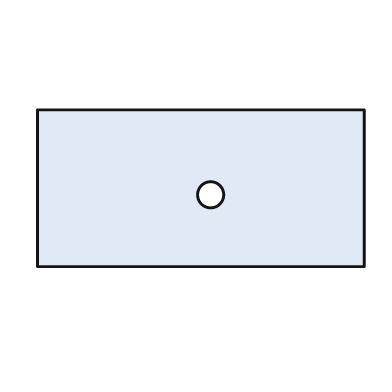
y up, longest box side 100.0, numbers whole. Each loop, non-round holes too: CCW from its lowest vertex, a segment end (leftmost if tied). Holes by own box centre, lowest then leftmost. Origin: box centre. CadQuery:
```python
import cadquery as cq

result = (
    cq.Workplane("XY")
    .moveTo(-50.0, -24.0)
    .lineTo(50.0, -24.0)
    .lineTo(50.0, 24.0)
    .lineTo(-50.0, 24.0)
    .close()
    .moveTo(3.0, -2.0)
    .circle(4.0)
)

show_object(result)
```